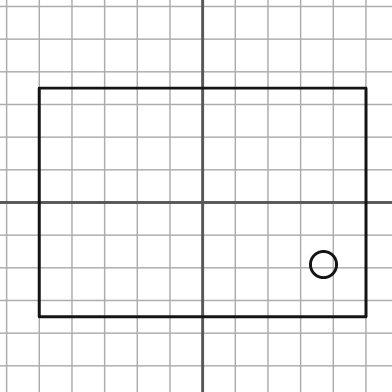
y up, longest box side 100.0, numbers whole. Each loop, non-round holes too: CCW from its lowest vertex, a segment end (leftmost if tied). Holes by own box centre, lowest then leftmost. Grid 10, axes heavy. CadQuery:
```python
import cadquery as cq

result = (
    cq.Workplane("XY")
    .moveTo(-50.0, -35.0)
    .lineTo(50.0, -35.0)
    .lineTo(50.0, 35.0)
    .lineTo(-50.0, 35.0)
    .close()
    .moveTo(37.0, -19.0)
    .circle(4.0)
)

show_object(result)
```